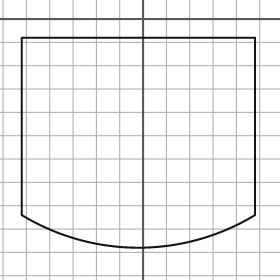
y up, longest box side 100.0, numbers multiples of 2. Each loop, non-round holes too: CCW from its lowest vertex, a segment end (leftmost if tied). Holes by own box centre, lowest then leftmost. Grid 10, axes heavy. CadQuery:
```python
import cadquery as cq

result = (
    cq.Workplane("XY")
    .moveTo(-52.0, -84.0)
    .threePointArc((-2.0, -98.0), (48.0, -84.0))
    .lineTo(48.0, -8.0)
    .lineTo(-52.0, -8.0)
    .close()
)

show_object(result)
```